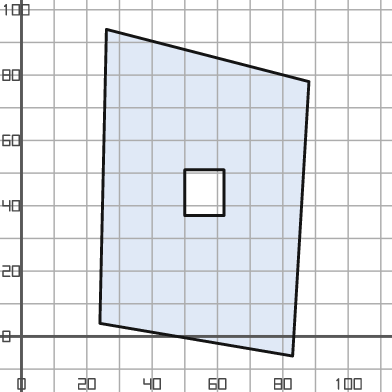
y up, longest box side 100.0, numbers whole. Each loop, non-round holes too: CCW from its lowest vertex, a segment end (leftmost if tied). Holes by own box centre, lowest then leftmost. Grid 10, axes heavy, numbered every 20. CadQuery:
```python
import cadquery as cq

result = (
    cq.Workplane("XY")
    .moveTo(83.0, -6.0)
    .lineTo(88.0, 78.0)
    .lineTo(26.0, 94.0)
    .lineTo(24.0, 4.0)
    .close()
    .moveTo(50.0, 37.0)
    .lineTo(62.0, 37.0)
    .lineTo(62.0, 51.0)
    .lineTo(50.0, 51.0)
    .close()
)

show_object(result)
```